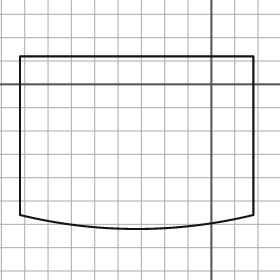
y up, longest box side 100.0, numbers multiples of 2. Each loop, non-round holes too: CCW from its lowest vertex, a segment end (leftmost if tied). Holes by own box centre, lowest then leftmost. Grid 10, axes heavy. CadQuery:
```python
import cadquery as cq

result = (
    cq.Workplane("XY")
    .moveTo(-82.0, -56.0)
    .threePointArc((-32.0, -62.0), (18.0, -56.0))
    .lineTo(18.0, 12.0)
    .lineTo(-82.0, 12.0)
    .close()
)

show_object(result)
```